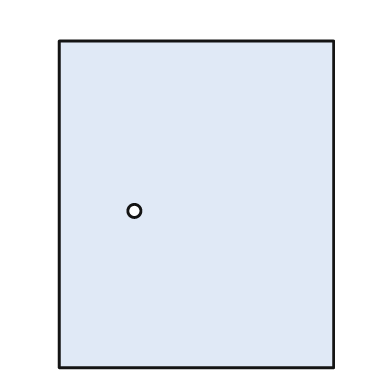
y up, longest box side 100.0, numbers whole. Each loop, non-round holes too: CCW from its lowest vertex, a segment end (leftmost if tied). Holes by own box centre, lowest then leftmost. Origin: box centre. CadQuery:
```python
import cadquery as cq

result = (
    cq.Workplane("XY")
    .moveTo(-42.0, -50.0)
    .lineTo(42.0, -50.0)
    .lineTo(42.0, 50.0)
    .lineTo(-42.0, 50.0)
    .close()
    .moveTo(-19.0, -2.0)
    .circle(2.0)
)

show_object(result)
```